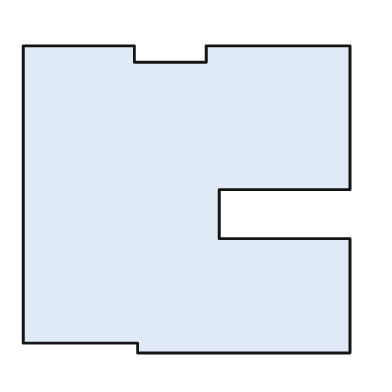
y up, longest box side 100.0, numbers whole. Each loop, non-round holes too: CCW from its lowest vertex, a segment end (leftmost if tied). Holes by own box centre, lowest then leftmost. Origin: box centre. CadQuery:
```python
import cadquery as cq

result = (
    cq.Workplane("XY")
    .moveTo(-15.0, -47.0)
    .lineTo(50.0, -47.0)
    .lineTo(50.0, -12.0)
    .lineTo(10.0, -12.0)
    .lineTo(10.0, 3.0)
    .lineTo(50.0, 3.0)
    .lineTo(50.0, 47.0)
    .lineTo(6.0, 47.0)
    .lineTo(6.0, 42.0)
    .lineTo(-16.0, 42.0)
    .lineTo(-16.0, 47.0)
    .lineTo(-50.0, 47.0)
    .lineTo(-50.0, -44.0)
    .lineTo(-15.0, -44.0)
    .close()
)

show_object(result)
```